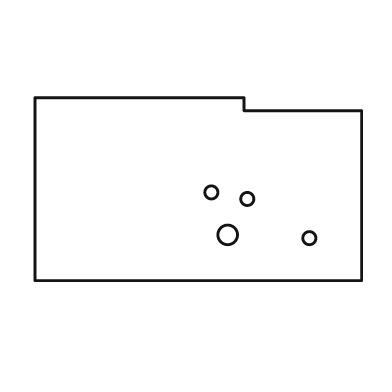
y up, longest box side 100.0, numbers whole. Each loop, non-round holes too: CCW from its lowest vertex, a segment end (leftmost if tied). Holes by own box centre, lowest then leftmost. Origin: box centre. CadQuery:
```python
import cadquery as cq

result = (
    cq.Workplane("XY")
    .moveTo(-50.0, -28.0)
    .lineTo(50.0, -28.0)
    .lineTo(50.0, 24.0)
    .lineTo(14.0, 24.0)
    .lineTo(14.0, 28.0)
    .lineTo(-50.0, 28.0)
    .close()
    .moveTo(34.0, -15.0)
    .circle(2.0)
    .moveTo(9.0, -14.0)
    .circle(3.0)
    .moveTo(15.0, -3.0)
    .circle(2.0)
    .moveTo(4.0, -1.0)
    .circle(2.0)
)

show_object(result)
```